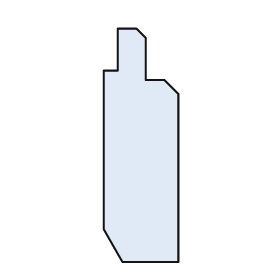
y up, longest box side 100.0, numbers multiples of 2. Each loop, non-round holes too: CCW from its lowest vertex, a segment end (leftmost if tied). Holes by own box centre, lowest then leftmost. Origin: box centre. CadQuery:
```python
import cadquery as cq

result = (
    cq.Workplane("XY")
    .moveTo(-8.0, -50.0)
    .lineTo(16.0, -50.0)
    .lineTo(16.0, 22.0)
    .lineTo(10.0, 28.0)
    .lineTo(2.0, 28.0)
    .lineTo(2.0, 46.0)
    .lineTo(-2.0, 50.0)
    .lineTo(-10.0, 50.0)
    .lineTo(-10.0, 32.0)
    .lineTo(-16.0, 32.0)
    .lineTo(-16.0, -36.0)
    .close()
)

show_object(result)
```